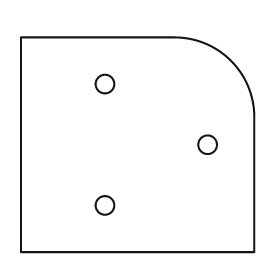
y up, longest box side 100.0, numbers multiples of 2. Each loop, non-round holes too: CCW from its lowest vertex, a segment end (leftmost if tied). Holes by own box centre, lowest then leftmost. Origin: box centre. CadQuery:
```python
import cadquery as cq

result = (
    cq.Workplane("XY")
    .moveTo(-50.0, -46.0)
    .lineTo(50.0, -46.0)
    .lineTo(50.0, 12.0)
    .threePointArc((40.0, 36.0), (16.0, 46.0))
    .lineTo(-50.0, 46.0)
    .close()
    .moveTo(-14.0, -26.0)
    .circle(4.0)
    .moveTo(30.0, 0.0)
    .circle(4.0)
    .moveTo(-14.0, 26.0)
    .circle(4.0)
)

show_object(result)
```